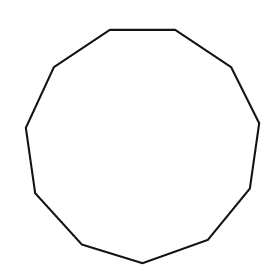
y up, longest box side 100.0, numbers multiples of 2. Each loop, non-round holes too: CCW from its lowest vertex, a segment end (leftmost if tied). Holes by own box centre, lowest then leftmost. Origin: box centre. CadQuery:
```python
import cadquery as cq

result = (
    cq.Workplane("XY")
    .moveTo(0.0, -50.0)
    .lineTo(28.0, -40.0)
    .lineTo(46.0, -18.0)
    .lineTo(50.0, 10.0)
    .lineTo(38.0, 34.0)
    .lineTo(14.0, 50.0)
    .lineTo(-14.0, 50.0)
    .lineTo(-38.0, 34.0)
    .lineTo(-50.0, 8.0)
    .lineTo(-46.0, -20.0)
    .lineTo(-26.0, -42.0)
    .close()
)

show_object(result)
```